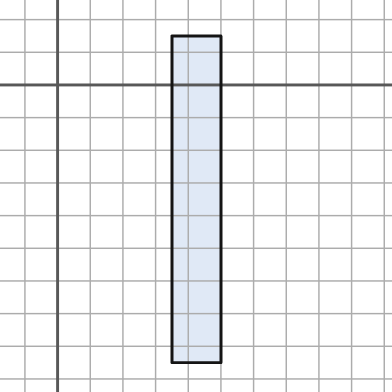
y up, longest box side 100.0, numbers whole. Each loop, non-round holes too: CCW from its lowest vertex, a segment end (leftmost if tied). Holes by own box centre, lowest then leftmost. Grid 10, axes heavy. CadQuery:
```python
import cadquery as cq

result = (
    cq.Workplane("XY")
    .moveTo(35.0, -85.0)
    .lineTo(50.0, -85.0)
    .lineTo(50.0, 15.0)
    .lineTo(35.0, 15.0)
    .close()
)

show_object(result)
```